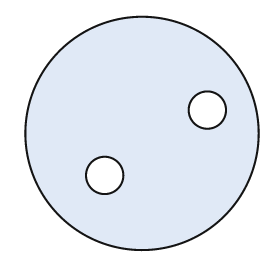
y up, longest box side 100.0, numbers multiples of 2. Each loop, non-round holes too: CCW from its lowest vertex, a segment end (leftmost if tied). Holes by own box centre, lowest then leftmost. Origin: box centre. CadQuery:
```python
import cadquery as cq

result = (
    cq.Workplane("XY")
    .moveTo(0.0, 0.0)
    .circle(50.0)
    .moveTo(-16.0, -18.0)
    .circle(8.0)
    .moveTo(28.0, 10.0)
    .circle(8.0)
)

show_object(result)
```